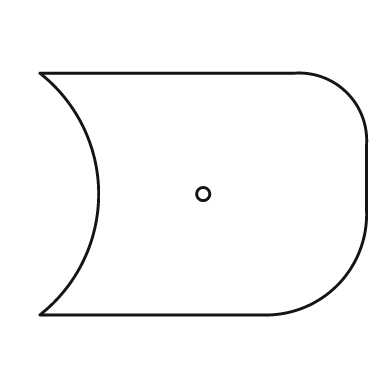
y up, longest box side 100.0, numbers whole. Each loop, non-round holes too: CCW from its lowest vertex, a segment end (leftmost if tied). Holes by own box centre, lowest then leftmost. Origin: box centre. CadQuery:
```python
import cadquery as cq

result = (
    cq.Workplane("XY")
    .moveTo(-50.0, -37.0)
    .lineTo(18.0, -37.0)
    .threePointArc((41.0, -28.0), (50.0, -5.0))
    .lineTo(50.0, 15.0)
    .threePointArc((44.0, 31.0), (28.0, 37.0))
    .lineTo(-50.0, 37.0)
    .threePointArc((-32.0, 0.0), (-50.0, -37.0))
    .close()
    .moveTo(0.0, 0.0)
    .circle(2.0)
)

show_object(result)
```